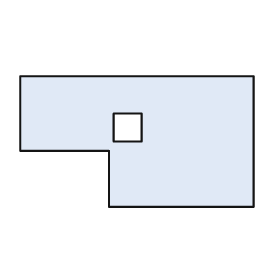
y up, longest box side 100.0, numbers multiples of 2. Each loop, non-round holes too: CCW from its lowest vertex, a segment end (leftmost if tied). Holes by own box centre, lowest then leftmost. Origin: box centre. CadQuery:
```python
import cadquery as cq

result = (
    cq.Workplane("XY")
    .moveTo(-12.0, -28.0)
    .lineTo(50.0, -28.0)
    .lineTo(50.0, 28.0)
    .lineTo(-50.0, 28.0)
    .lineTo(-50.0, -4.0)
    .lineTo(-12.0, -4.0)
    .close()
    .moveTo(-10.0, 0.0)
    .lineTo(2.0, 0.0)
    .lineTo(2.0, 12.0)
    .lineTo(-10.0, 12.0)
    .close()
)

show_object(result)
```